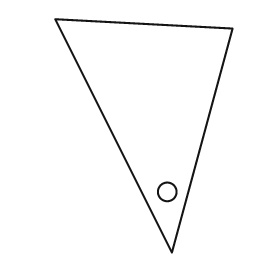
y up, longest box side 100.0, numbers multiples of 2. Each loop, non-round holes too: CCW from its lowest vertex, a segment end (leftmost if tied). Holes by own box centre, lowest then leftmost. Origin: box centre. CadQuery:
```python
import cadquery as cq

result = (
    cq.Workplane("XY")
    .moveTo(12.0, -50.0)
    .lineTo(38.0, 46.0)
    .lineTo(-38.0, 50.0)
    .close()
    .moveTo(10.0, -24.0)
    .circle(4.0)
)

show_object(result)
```